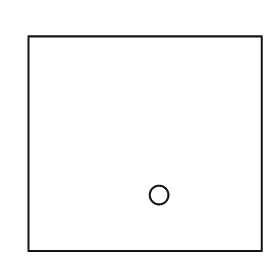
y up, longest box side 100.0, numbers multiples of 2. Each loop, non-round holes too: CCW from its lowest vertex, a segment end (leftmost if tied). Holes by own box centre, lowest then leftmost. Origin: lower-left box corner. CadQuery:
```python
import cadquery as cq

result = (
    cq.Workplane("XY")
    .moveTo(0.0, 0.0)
    .lineTo(100.0, 0.0)
    .lineTo(100.0, 92.0)
    .lineTo(0.0, 92.0)
    .close()
    .moveTo(56.0, 24.0)
    .circle(4.0)
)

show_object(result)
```